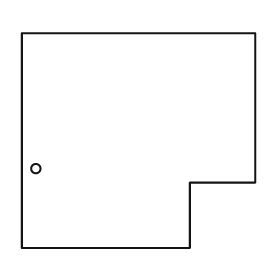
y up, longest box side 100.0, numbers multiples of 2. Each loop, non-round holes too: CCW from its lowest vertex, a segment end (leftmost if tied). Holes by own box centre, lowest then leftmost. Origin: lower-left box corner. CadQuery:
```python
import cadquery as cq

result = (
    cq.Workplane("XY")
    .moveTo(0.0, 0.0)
    .lineTo(72.0, 0.0)
    .lineTo(72.0, 28.0)
    .lineTo(100.0, 28.0)
    .lineTo(100.0, 92.0)
    .lineTo(0.0, 92.0)
    .close()
    .moveTo(6.0, 34.0)
    .circle(2.0)
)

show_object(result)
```